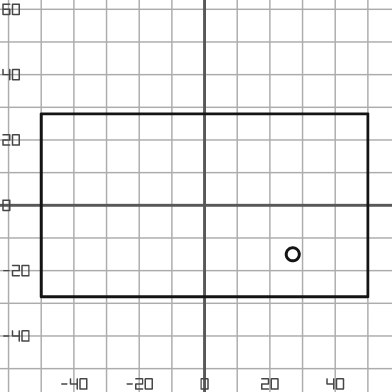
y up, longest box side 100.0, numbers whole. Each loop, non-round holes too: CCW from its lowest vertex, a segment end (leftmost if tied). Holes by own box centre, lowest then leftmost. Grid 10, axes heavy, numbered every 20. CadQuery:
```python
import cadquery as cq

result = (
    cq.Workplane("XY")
    .moveTo(-50.0, -28.0)
    .lineTo(50.0, -28.0)
    .lineTo(50.0, 28.0)
    .lineTo(-50.0, 28.0)
    .close()
    .moveTo(27.0, -15.0)
    .circle(2.0)
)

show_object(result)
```